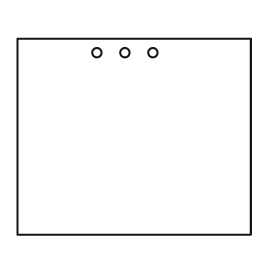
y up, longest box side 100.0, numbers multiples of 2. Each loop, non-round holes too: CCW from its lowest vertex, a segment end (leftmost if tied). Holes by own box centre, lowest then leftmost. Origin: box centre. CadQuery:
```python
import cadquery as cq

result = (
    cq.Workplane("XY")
    .moveTo(-50.0, -42.0)
    .lineTo(50.0, -42.0)
    .lineTo(50.0, 42.0)
    .lineTo(-50.0, 42.0)
    .close()
    .moveTo(-16.0, 36.0)
    .circle(2.0)
    .moveTo(-4.0, 36.0)
    .circle(2.0)
    .moveTo(8.0, 36.0)
    .circle(2.0)
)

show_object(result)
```